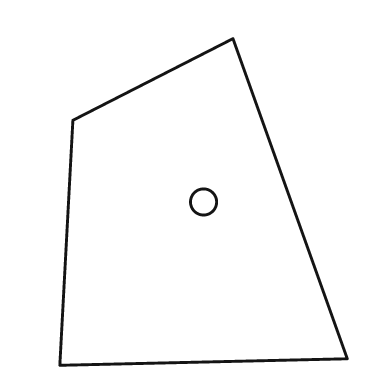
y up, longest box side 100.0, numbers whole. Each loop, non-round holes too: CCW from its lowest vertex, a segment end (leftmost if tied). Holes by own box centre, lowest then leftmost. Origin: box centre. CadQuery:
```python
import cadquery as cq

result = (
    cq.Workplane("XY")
    .moveTo(-44.0, -50.0)
    .lineTo(44.0, -48.0)
    .lineTo(9.0, 50.0)
    .lineTo(-40.0, 25.0)
    .close()
    .moveTo(0.0, 0.0)
    .circle(4.0)
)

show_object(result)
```